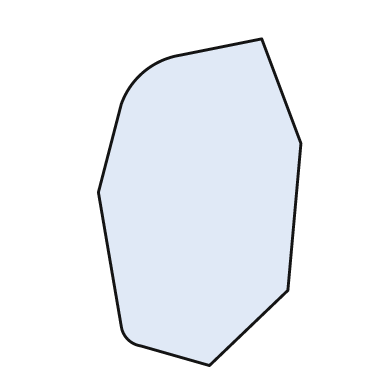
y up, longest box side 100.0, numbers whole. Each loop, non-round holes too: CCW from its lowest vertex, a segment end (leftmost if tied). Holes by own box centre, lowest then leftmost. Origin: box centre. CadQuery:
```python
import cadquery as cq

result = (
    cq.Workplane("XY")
    .moveTo(3.0, -50.0)
    .lineTo(27.0, -27.0)
    .lineTo(31.0, 18.0)
    .lineTo(19.0, 50.0)
    .lineTo(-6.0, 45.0)
    .threePointArc((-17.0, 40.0), (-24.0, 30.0))
    .lineTo(-31.0, 3.0)
    .lineTo(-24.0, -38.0)
    .threePointArc((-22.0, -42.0), (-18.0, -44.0))
    .close()
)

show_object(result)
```